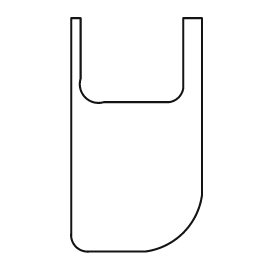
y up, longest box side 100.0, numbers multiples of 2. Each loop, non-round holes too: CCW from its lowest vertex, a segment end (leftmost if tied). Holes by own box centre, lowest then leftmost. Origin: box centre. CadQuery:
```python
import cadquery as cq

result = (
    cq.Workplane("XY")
    .moveTo(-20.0, -50.0)
    .lineTo(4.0, -50.0)
    .threePointArc((20.0, -42.0), (28.0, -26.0))
    .lineTo(28.0, 50.0)
    .lineTo(20.0, 50.0)
    .lineTo(20.0, 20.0)
    .threePointArc((18.0, 16.0), (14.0, 14.0))
    .lineTo(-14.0, 14.0)
    .threePointArc((-22.0, 16.0), (-24.0, 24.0))
    .lineTo(-24.0, 50.0)
    .lineTo(-28.0, 50.0)
    .lineTo(-28.0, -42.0)
    .threePointArc((-26.0, -48.0), (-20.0, -50.0))
    .close()
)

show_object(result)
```